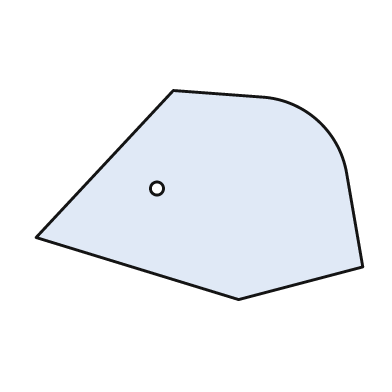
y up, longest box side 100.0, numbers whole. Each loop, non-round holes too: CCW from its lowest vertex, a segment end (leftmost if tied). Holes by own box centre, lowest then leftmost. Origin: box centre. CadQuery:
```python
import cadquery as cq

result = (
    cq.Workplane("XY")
    .moveTo(12.0, -32.0)
    .lineTo(50.0, -22.0)
    .lineTo(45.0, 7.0)
    .threePointArc((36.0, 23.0), (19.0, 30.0))
    .lineTo(-8.0, 32.0)
    .lineTo(-50.0, -13.0)
    .close()
    .moveTo(-13.0, 2.0)
    .circle(2.0)
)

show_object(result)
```